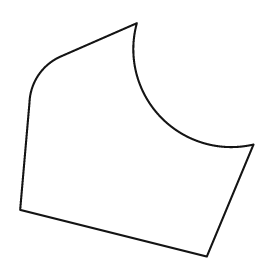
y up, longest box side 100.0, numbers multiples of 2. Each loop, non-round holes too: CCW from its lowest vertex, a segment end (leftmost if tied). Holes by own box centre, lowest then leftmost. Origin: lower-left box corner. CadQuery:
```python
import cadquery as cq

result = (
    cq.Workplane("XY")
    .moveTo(80.0, 0.0)
    .lineTo(100.0, 48.0)
    .threePointArc((60.0, 60.0), (50.0, 100.0))
    .lineTo(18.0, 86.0)
    .threePointArc((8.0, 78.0), (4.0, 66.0))
    .lineTo(0.0, 20.0)
    .close()
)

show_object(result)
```